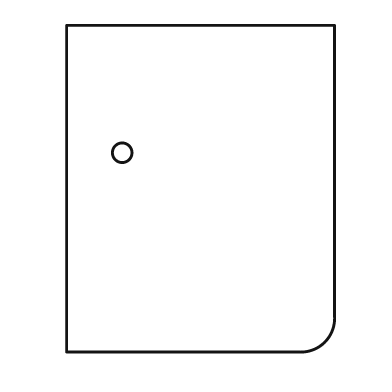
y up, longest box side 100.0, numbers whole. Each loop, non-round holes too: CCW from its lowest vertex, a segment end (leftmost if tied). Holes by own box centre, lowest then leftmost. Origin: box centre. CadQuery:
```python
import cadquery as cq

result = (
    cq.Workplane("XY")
    .moveTo(-41.0, -50.0)
    .lineTo(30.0, -50.0)
    .threePointArc((38.0, -47.0), (41.0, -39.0))
    .lineTo(41.0, 50.0)
    .lineTo(-41.0, 50.0)
    .close()
    .moveTo(-24.0, 11.0)
    .circle(3.0)
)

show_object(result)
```